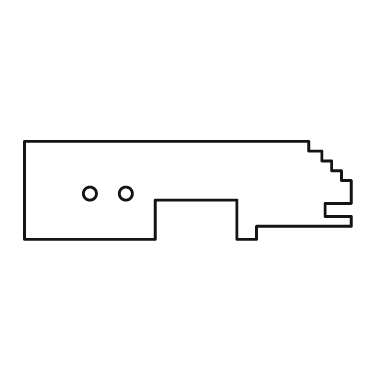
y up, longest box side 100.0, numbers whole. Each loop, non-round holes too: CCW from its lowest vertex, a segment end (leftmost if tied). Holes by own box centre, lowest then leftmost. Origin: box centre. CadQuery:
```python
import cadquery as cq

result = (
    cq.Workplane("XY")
    .moveTo(-50.0, -15.0)
    .lineTo(-10.0, -15.0)
    .lineTo(-10.0, -3.0)
    .lineTo(15.0, -3.0)
    .lineTo(15.0, -15.0)
    .lineTo(21.0, -15.0)
    .lineTo(21.0, -11.0)
    .lineTo(50.0, -11.0)
    .lineTo(50.0, -8.0)
    .lineTo(42.0, -8.0)
    .lineTo(42.0, -4.0)
    .lineTo(50.0, -4.0)
    .lineTo(50.0, 3.0)
    .lineTo(47.0, 3.0)
    .lineTo(47.0, 6.0)
    .lineTo(44.0, 6.0)
    .lineTo(44.0, 9.0)
    .lineTo(41.0, 9.0)
    .lineTo(41.0, 12.0)
    .lineTo(37.0, 12.0)
    .lineTo(37.0, 15.0)
    .lineTo(-50.0, 15.0)
    .close()
    .moveTo(-30.0, -1.0)
    .circle(2.0)
    .moveTo(-19.0, -1.0)
    .circle(2.0)
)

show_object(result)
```